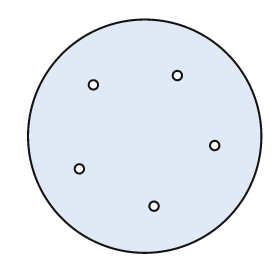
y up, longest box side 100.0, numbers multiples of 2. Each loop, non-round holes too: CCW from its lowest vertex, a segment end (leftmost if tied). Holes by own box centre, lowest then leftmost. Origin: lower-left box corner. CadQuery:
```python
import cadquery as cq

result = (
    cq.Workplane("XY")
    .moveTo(50.0, 50.0)
    .circle(50.0)
    .moveTo(54.0, 20.0)
    .circle(2.0)
    .moveTo(22.0, 36.0)
    .circle(2.0)
    .moveTo(80.0, 46.0)
    .circle(2.0)
    .moveTo(28.0, 72.0)
    .circle(2.0)
    .moveTo(64.0, 76.0)
    .circle(2.0)
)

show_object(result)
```